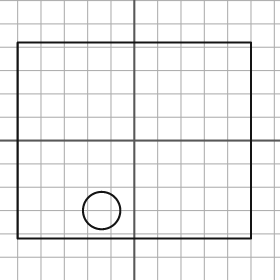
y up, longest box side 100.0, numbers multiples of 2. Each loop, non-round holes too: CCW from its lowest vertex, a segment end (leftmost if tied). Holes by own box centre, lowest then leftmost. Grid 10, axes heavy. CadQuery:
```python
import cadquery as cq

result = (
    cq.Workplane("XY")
    .moveTo(-50.0, -42.0)
    .lineTo(50.0, -42.0)
    .lineTo(50.0, 42.0)
    .lineTo(-50.0, 42.0)
    .close()
    .moveTo(-14.0, -30.0)
    .circle(8.0)
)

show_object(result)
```